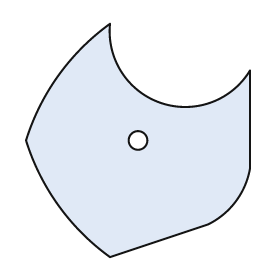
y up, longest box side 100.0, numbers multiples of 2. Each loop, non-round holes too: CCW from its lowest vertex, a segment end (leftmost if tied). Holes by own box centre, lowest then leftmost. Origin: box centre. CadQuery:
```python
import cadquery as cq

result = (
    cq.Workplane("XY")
    .moveTo(-12.0, -50.0)
    .lineTo(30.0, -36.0)
    .threePointArc((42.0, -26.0), (48.0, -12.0))
    .lineTo(48.0, 30.0)
    .threePointArc((10.0, 16.0), (-12.0, 50.0))
    .threePointArc((-34.0, 28.0), (-48.0, 0.0))
    .threePointArc((-34.0, -28.0), (-12.0, -50.0))
    .close()
    .moveTo(0.0, 0.0)
    .circle(4.0)
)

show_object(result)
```